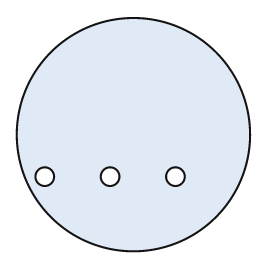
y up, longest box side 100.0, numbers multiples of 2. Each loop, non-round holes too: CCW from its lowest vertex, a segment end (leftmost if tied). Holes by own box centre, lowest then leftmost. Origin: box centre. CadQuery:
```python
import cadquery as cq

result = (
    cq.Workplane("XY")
    .moveTo(0.0, 0.0)
    .circle(50.0)
    .moveTo(-38.0, -18.0)
    .circle(4.0)
    .moveTo(-10.0, -18.0)
    .circle(4.0)
    .moveTo(18.0, -18.0)
    .circle(4.0)
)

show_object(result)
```